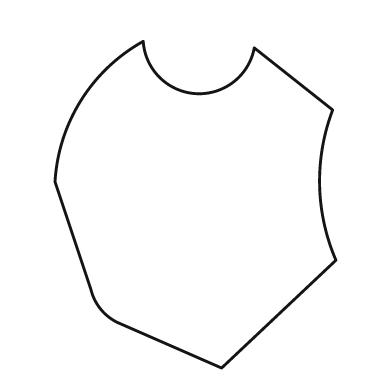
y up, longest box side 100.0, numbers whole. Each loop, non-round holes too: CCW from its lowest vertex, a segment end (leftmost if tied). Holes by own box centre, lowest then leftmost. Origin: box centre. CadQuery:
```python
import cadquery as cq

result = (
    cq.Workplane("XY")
    .moveTo(8.0, -50.0)
    .lineTo(43.0, -17.0)
    .threePointArc((38.0, 6.0), (42.0, 29.0))
    .lineTo(18.0, 48.0)
    .threePointArc((0.0, 34.0), (-16.0, 50.0))
    .threePointArc((-35.0, 32.0), (-43.0, 7.0))
    .lineTo(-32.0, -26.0)
    .threePointArc((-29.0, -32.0), (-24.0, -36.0))
    .close()
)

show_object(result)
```